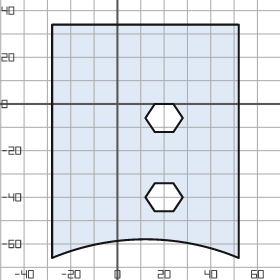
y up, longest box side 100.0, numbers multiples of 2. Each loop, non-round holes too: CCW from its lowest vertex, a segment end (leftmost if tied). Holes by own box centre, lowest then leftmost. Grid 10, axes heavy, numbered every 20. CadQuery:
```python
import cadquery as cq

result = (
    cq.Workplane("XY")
    .moveTo(-28.0, -66.0)
    .threePointArc((12.0, -58.0), (52.0, -66.0))
    .lineTo(52.0, 34.0)
    .lineTo(-28.0, 34.0)
    .close()
    .moveTo(16.0, -46.0)
    .lineTo(24.0, -46.0)
    .lineTo(28.0, -40.0)
    .lineTo(24.0, -34.0)
    .lineTo(16.0, -34.0)
    .lineTo(12.0, -40.0)
    .close()
    .moveTo(16.0, -12.0)
    .lineTo(24.0, -12.0)
    .lineTo(28.0, -6.0)
    .lineTo(24.0, 0.0)
    .lineTo(16.0, 0.0)
    .lineTo(12.0, -6.0)
    .close()
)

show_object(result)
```